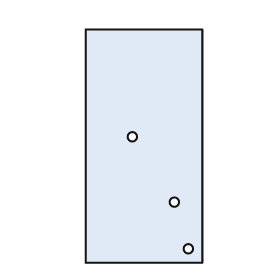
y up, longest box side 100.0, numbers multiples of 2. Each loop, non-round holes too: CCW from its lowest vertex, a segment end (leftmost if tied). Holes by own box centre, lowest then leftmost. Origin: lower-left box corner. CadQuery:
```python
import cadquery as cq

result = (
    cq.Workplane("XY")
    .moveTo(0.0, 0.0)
    .lineTo(50.0, 0.0)
    .lineTo(50.0, 100.0)
    .lineTo(0.0, 100.0)
    .close()
    .moveTo(44.0, 6.0)
    .circle(2.0)
    .moveTo(38.0, 26.0)
    .circle(2.0)
    .moveTo(20.0, 54.0)
    .circle(2.0)
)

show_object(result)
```